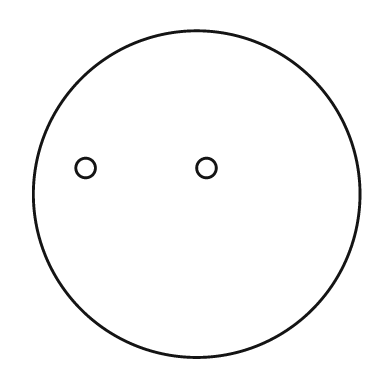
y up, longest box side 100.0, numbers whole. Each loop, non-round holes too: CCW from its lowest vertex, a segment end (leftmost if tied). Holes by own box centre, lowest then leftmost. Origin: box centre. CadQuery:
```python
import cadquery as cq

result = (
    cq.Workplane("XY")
    .moveTo(0.0, 0.0)
    .circle(50.0)
    .moveTo(-34.0, 8.0)
    .circle(3.0)
    .moveTo(3.0, 8.0)
    .circle(3.0)
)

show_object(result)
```